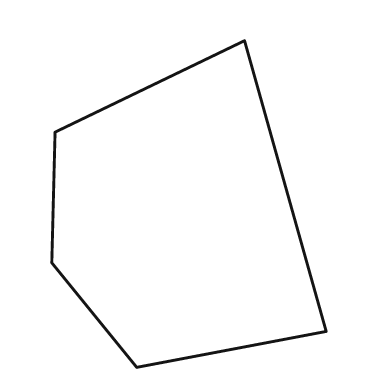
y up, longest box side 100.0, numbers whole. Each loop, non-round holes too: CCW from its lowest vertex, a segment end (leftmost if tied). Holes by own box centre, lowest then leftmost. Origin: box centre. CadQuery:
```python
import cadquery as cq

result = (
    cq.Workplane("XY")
    .moveTo(-16.0, -50.0)
    .lineTo(42.0, -39.0)
    .lineTo(17.0, 50.0)
    .lineTo(-41.0, 22.0)
    .lineTo(-42.0, -18.0)
    .close()
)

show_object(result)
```